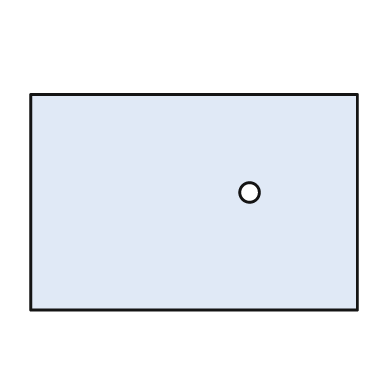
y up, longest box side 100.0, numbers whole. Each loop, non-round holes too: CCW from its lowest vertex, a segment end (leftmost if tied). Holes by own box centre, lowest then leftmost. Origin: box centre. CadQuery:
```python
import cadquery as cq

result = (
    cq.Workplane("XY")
    .moveTo(-50.0, -33.0)
    .lineTo(50.0, -33.0)
    .lineTo(50.0, 33.0)
    .lineTo(-50.0, 33.0)
    .close()
    .moveTo(17.0, 3.0)
    .circle(3.0)
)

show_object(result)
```